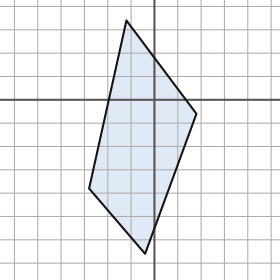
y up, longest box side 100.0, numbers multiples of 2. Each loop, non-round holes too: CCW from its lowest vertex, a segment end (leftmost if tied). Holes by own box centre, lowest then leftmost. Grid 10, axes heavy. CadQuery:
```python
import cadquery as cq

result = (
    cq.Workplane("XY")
    .moveTo(-4.0, -66.0)
    .lineTo(18.0, -6.0)
    .lineTo(-12.0, 34.0)
    .lineTo(-28.0, -38.0)
    .close()
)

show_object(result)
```